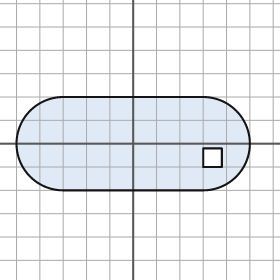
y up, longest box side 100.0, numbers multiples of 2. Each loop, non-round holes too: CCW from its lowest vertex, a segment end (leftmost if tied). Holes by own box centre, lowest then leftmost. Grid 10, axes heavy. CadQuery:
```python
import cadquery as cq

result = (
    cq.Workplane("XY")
    .moveTo(-30.0, -20.0)
    .lineTo(30.0, -20.0)
    .threePointArc((50.0, 0.0), (30.0, 20.0))
    .lineTo(-30.0, 20.0)
    .threePointArc((-50.0, 0.0), (-30.0, -20.0))
    .close()
    .moveTo(30.0, -10.0)
    .lineTo(38.0, -10.0)
    .lineTo(38.0, -2.0)
    .lineTo(30.0, -2.0)
    .close()
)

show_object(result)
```